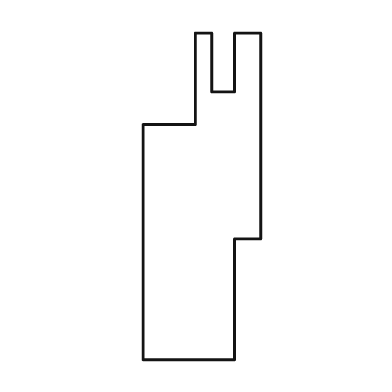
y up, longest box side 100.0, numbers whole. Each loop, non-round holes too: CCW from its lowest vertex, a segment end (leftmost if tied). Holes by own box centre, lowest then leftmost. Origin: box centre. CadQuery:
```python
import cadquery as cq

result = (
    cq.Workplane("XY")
    .moveTo(-18.0, -50.0)
    .lineTo(10.0, -50.0)
    .lineTo(10.0, -13.0)
    .lineTo(18.0, -13.0)
    .lineTo(18.0, 50.0)
    .lineTo(10.0, 50.0)
    .lineTo(10.0, 32.0)
    .lineTo(3.0, 32.0)
    .lineTo(3.0, 50.0)
    .lineTo(-2.0, 50.0)
    .lineTo(-2.0, 22.0)
    .lineTo(-18.0, 22.0)
    .close()
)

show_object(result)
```